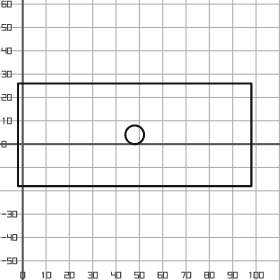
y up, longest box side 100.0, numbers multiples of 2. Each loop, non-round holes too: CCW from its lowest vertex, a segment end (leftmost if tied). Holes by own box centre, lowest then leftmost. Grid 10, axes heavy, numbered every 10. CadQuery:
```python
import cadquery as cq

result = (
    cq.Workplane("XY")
    .moveTo(-2.0, -18.0)
    .lineTo(98.0, -18.0)
    .lineTo(98.0, 26.0)
    .lineTo(-2.0, 26.0)
    .close()
    .moveTo(48.0, 4.0)
    .circle(4.0)
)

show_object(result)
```